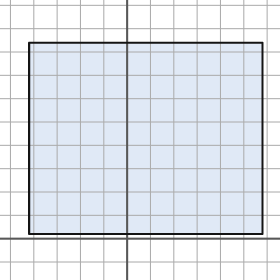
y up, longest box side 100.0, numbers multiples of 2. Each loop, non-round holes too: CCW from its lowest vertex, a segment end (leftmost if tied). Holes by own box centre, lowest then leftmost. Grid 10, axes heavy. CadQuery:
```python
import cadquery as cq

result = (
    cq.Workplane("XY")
    .moveTo(-42.0, 2.0)
    .lineTo(58.0, 2.0)
    .lineTo(58.0, 84.0)
    .lineTo(-42.0, 84.0)
    .close()
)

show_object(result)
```